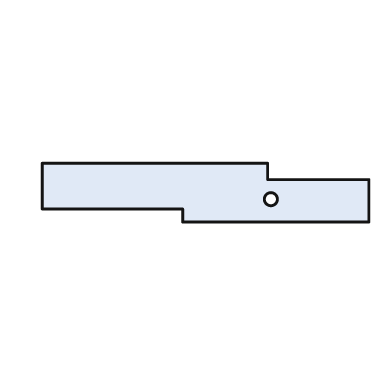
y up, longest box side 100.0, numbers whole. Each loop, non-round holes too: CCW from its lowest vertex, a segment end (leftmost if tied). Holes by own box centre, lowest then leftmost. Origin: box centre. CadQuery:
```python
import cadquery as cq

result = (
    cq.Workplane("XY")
    .moveTo(-7.0, -9.0)
    .lineTo(50.0, -9.0)
    .lineTo(50.0, 4.0)
    .lineTo(19.0, 4.0)
    .lineTo(19.0, 9.0)
    .lineTo(-50.0, 9.0)
    .lineTo(-50.0, -5.0)
    .lineTo(-7.0, -5.0)
    .close()
    .moveTo(20.0, -2.0)
    .circle(2.0)
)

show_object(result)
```